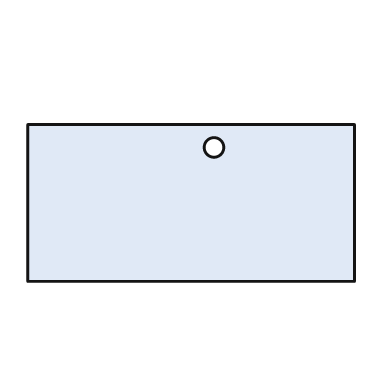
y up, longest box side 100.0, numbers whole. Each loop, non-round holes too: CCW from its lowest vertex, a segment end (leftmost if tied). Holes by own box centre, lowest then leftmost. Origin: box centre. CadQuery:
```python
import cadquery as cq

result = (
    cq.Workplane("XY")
    .moveTo(-50.0, -24.0)
    .lineTo(50.0, -24.0)
    .lineTo(50.0, 24.0)
    .lineTo(-50.0, 24.0)
    .close()
    .moveTo(7.0, 17.0)
    .circle(3.0)
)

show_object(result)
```